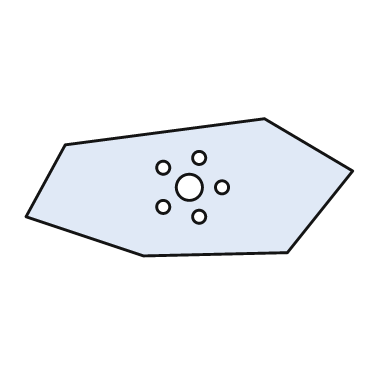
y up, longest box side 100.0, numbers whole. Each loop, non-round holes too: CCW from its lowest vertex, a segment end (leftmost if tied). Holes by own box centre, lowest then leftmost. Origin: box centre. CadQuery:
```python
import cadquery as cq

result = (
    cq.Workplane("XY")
    .moveTo(-14.0, -21.0)
    .lineTo(30.0, -20.0)
    .lineTo(50.0, 5.0)
    .lineTo(23.0, 21.0)
    .lineTo(-38.0, 13.0)
    .lineTo(-50.0, -9.0)
    .close()
    .moveTo(3.0, -9.0)
    .circle(2.0)
    .moveTo(-8.0, -6.0)
    .circle(2.0)
    .moveTo(0.0, 0.0)
    .circle(4.0)
    .moveTo(10.0, 0.0)
    .circle(2.0)
    .moveTo(-8.0, 6.0)
    .circle(2.0)
    .moveTo(3.0, 9.0)
    .circle(2.0)
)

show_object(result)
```